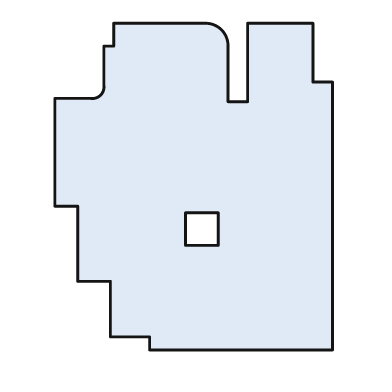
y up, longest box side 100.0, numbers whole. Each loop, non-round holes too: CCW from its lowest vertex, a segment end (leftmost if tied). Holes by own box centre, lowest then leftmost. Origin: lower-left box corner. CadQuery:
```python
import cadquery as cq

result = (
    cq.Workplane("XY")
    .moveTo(29.0, 0.0)
    .lineTo(85.0, 0.0)
    .lineTo(85.0, 82.0)
    .lineTo(79.0, 82.0)
    .lineTo(79.0, 100.0)
    .lineTo(59.0, 100.0)
    .lineTo(59.0, 76.0)
    .lineTo(53.0, 76.0)
    .lineTo(53.0, 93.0)
    .threePointArc((51.0, 98.0), (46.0, 100.0))
    .lineTo(18.0, 100.0)
    .lineTo(18.0, 93.0)
    .lineTo(15.0, 93.0)
    .lineTo(15.0, 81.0)
    .threePointArc((14.0, 78.0), (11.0, 77.0))
    .lineTo(0.0, 77.0)
    .lineTo(0.0, 44.0)
    .lineTo(7.0, 44.0)
    .lineTo(7.0, 21.0)
    .lineTo(17.0, 21.0)
    .lineTo(17.0, 4.0)
    .lineTo(29.0, 4.0)
    .close()
    .moveTo(40.0, 32.0)
    .lineTo(50.0, 32.0)
    .lineTo(50.0, 42.0)
    .lineTo(40.0, 42.0)
    .close()
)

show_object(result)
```